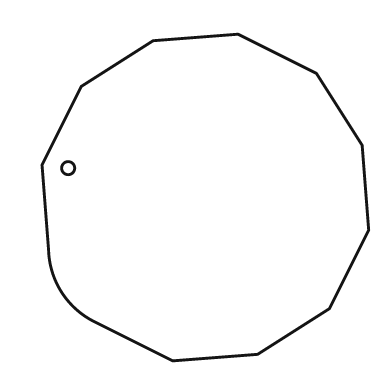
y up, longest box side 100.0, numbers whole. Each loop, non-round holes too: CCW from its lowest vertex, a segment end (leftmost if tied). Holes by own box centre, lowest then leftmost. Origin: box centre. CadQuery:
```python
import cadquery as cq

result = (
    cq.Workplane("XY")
    .moveTo(-10.0, -50.0)
    .lineTo(16.0, -48.0)
    .lineTo(38.0, -34.0)
    .lineTo(50.0, -10.0)
    .lineTo(48.0, 16.0)
    .lineTo(34.0, 38.0)
    .lineTo(10.0, 50.0)
    .lineTo(-16.0, 48.0)
    .lineTo(-38.0, 34.0)
    .lineTo(-50.0, 10.0)
    .lineTo(-48.0, -16.0)
    .threePointArc((-44.0, -29.0), (-34.0, -38.0))
    .close()
    .moveTo(-42.0, 9.0)
    .circle(2.0)
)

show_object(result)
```